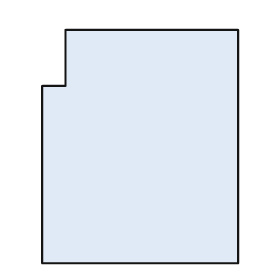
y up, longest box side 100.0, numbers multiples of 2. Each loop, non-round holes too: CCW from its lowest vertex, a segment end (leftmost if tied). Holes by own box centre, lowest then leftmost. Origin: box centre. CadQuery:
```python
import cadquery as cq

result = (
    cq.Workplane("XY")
    .moveTo(-42.0, -50.0)
    .lineTo(42.0, -50.0)
    .lineTo(42.0, 50.0)
    .lineTo(-32.0, 50.0)
    .lineTo(-32.0, 26.0)
    .lineTo(-42.0, 26.0)
    .close()
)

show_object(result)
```